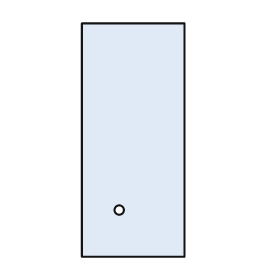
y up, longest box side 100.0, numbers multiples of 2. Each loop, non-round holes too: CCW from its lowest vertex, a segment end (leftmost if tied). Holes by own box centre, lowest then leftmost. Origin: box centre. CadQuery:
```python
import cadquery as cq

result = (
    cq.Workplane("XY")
    .moveTo(-22.0, -50.0)
    .lineTo(22.0, -50.0)
    .lineTo(22.0, 50.0)
    .lineTo(-22.0, 50.0)
    .close()
    .moveTo(-6.0, -30.0)
    .circle(2.0)
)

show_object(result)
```